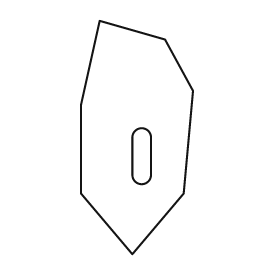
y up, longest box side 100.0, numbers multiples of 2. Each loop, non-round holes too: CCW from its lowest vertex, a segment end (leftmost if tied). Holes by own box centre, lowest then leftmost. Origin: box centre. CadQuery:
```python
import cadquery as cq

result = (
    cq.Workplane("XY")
    .moveTo(-2.0, -50.0)
    .lineTo(20.0, -24.0)
    .lineTo(24.0, 20.0)
    .lineTo(12.0, 42.0)
    .lineTo(-16.0, 50.0)
    .lineTo(-24.0, 14.0)
    .lineTo(-24.0, -24.0)
    .close()
    .moveTo(-2.0, -16.0)
    .threePointArc((2.0, -20.0), (6.0, -16.0))
    .lineTo(6.0, 0.0)
    .threePointArc((2.0, 4.0), (-2.0, 0.0))
    .close()
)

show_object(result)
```